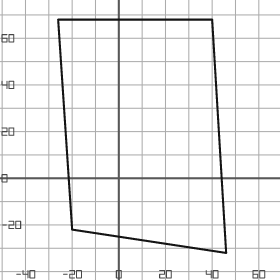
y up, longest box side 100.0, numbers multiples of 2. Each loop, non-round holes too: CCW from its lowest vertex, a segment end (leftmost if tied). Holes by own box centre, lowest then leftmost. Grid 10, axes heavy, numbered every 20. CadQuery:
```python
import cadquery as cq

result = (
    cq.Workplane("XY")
    .moveTo(46.0, -32.0)
    .lineTo(40.0, 68.0)
    .lineTo(-26.0, 68.0)
    .lineTo(-20.0, -22.0)
    .close()
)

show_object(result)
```